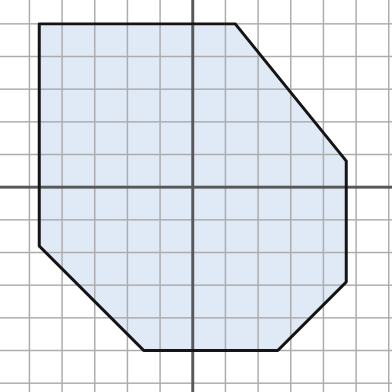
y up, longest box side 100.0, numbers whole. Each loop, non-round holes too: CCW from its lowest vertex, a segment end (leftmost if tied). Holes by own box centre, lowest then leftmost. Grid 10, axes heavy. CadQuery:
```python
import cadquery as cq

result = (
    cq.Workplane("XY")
    .moveTo(-15.0, -50.0)
    .lineTo(26.0, -50.0)
    .lineTo(47.0, -29.0)
    .lineTo(47.0, 8.0)
    .lineTo(13.0, 50.0)
    .lineTo(-47.0, 50.0)
    .lineTo(-47.0, -18.0)
    .close()
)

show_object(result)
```